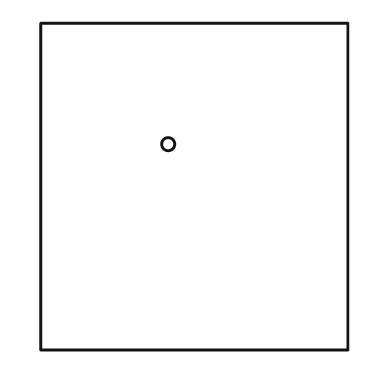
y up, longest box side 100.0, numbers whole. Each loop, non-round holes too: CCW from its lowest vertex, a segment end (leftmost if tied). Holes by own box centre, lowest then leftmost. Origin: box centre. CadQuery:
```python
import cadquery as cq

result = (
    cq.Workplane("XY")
    .moveTo(-47.0, -50.0)
    .lineTo(47.0, -50.0)
    .lineTo(47.0, 50.0)
    .lineTo(-47.0, 50.0)
    .close()
    .moveTo(-8.0, 13.0)
    .circle(2.0)
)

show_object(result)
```